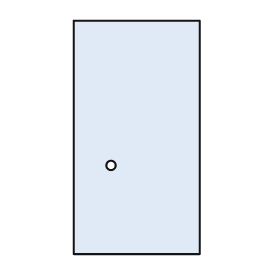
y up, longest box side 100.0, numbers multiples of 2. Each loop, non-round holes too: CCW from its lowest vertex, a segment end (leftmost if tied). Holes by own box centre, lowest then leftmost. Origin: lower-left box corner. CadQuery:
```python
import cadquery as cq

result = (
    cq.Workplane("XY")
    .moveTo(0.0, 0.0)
    .lineTo(54.0, 0.0)
    .lineTo(54.0, 100.0)
    .lineTo(0.0, 100.0)
    .close()
    .moveTo(16.0, 38.0)
    .circle(2.0)
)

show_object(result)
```